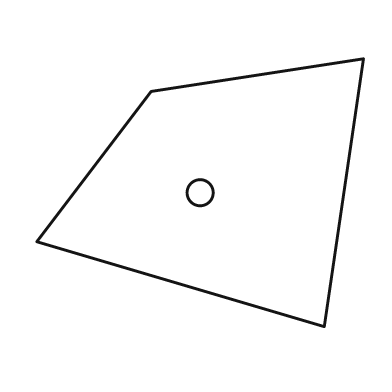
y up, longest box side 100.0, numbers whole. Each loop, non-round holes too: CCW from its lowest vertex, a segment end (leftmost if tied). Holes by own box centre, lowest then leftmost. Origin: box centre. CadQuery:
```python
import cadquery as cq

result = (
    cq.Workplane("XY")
    .moveTo(38.0, -41.0)
    .lineTo(50.0, 41.0)
    .lineTo(-15.0, 31.0)
    .lineTo(-50.0, -15.0)
    .close()
    .moveTo(0.0, 0.0)
    .circle(4.0)
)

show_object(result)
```